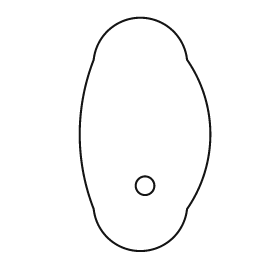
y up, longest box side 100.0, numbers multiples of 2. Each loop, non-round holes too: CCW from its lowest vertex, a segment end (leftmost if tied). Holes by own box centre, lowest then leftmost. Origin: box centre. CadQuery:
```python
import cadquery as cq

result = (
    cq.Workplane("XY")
    .moveTo(-22.0, -32.0)
    .threePointArc((-2.0, -50.0), (18.0, -32.0))
    .threePointArc((28.0, 0.0), (18.0, 32.0))
    .threePointArc((-2.0, 50.0), (-22.0, 32.0))
    .threePointArc((-28.0, 0.0), (-22.0, -32.0))
    .close()
    .moveTo(0.0, -22.0)
    .circle(4.0)
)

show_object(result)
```